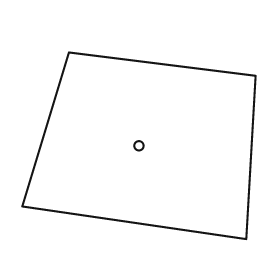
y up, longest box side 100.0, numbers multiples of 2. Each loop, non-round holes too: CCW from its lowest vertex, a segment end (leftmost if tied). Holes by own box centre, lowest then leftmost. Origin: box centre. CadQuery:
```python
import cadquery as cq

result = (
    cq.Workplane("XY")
    .moveTo(46.0, -40.0)
    .lineTo(50.0, 30.0)
    .lineTo(-30.0, 40.0)
    .lineTo(-50.0, -26.0)
    .close()
    .moveTo(0.0, 0.0)
    .circle(2.0)
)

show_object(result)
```